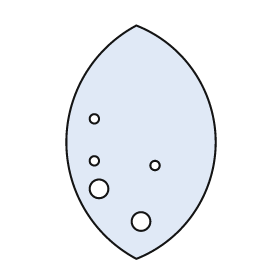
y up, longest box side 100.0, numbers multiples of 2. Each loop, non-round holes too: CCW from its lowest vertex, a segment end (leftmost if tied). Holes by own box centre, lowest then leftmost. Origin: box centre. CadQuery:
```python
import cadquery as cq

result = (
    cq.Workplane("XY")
    .moveTo(-2.0, -50.0)
    .threePointArc((32.0, 0.0), (-2.0, 50.0))
    .threePointArc((-32.0, 0.0), (-2.0, -50.0))
    .close()
    .moveTo(0.0, -34.0)
    .circle(4.0)
    .moveTo(-18.0, -20.0)
    .circle(4.0)
    .moveTo(6.0, -10.0)
    .circle(2.0)
    .moveTo(-20.0, -8.0)
    .circle(2.0)
    .moveTo(-20.0, 10.0)
    .circle(2.0)
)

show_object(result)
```